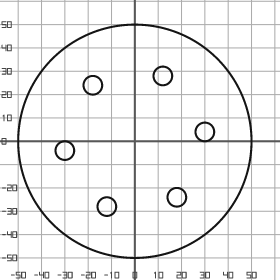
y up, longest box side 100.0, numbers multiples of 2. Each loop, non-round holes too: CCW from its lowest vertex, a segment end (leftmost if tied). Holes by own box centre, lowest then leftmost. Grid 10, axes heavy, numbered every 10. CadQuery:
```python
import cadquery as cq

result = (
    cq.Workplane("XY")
    .moveTo(0.0, 0.0)
    .circle(50.0)
    .moveTo(-12.0, -28.0)
    .circle(4.0)
    .moveTo(18.0, -24.0)
    .circle(4.0)
    .moveTo(-30.0, -4.0)
    .circle(4.0)
    .moveTo(30.0, 4.0)
    .circle(4.0)
    .moveTo(-18.0, 24.0)
    .circle(4.0)
    .moveTo(12.0, 28.0)
    .circle(4.0)
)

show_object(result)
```